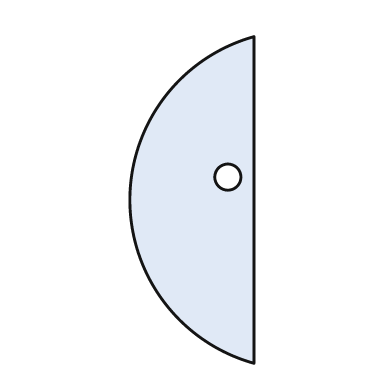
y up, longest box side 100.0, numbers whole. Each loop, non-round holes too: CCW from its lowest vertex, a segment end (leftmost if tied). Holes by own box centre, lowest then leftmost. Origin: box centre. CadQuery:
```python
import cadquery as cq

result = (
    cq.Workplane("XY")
    .moveTo(19.0, -50.0)
    .lineTo(19.0, 50.0)
    .threePointArc((-19.0, 0.0), (19.0, -50.0))
    .close()
    .moveTo(11.0, 7.0)
    .circle(4.0)
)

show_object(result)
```